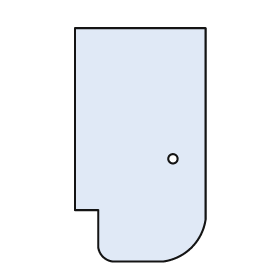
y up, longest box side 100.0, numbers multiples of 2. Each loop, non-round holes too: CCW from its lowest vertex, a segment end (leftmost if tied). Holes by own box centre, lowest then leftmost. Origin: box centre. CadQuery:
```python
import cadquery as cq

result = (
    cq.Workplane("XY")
    .moveTo(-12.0, -50.0)
    .lineTo(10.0, -50.0)
    .threePointArc((22.0, -44.0), (28.0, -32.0))
    .lineTo(28.0, 50.0)
    .lineTo(-28.0, 50.0)
    .lineTo(-28.0, -28.0)
    .lineTo(-18.0, -28.0)
    .lineTo(-18.0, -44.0)
    .threePointArc((-16.0, -48.0), (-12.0, -50.0))
    .close()
    .moveTo(14.0, -6.0)
    .circle(2.0)
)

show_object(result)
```